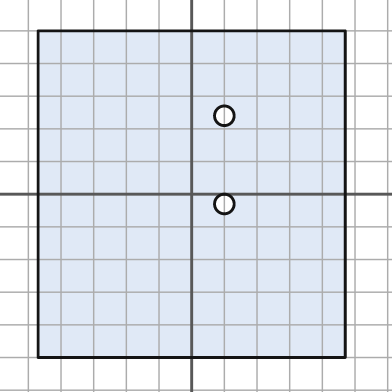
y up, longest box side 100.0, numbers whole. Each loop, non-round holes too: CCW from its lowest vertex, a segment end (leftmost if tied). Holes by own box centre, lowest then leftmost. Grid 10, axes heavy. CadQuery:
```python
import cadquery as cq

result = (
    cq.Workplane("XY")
    .moveTo(-47.0, -50.0)
    .lineTo(47.0, -50.0)
    .lineTo(47.0, 50.0)
    .lineTo(-47.0, 50.0)
    .close()
    .moveTo(10.0, -3.0)
    .circle(3.0)
    .moveTo(10.0, 24.0)
    .circle(3.0)
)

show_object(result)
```